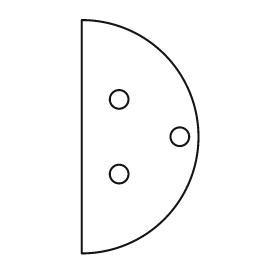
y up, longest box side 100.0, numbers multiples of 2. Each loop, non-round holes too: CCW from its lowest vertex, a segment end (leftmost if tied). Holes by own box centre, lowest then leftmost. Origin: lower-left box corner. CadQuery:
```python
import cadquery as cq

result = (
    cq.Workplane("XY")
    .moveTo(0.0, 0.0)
    .threePointArc((50.0, 50.0), (0.0, 100.0))
    .close()
    .moveTo(16.0, 34.0)
    .circle(4.0)
    .moveTo(42.0, 50.0)
    .circle(4.0)
    .moveTo(16.0, 66.0)
    .circle(4.0)
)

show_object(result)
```